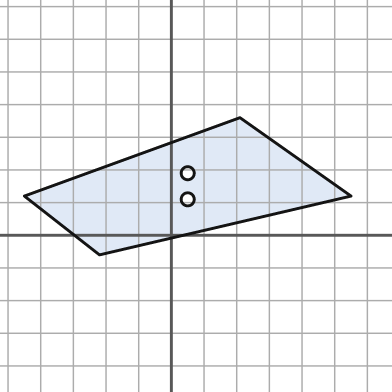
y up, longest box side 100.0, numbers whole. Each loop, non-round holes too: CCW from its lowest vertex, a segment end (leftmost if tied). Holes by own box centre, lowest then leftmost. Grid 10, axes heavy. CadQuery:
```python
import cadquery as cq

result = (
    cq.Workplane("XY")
    .moveTo(-22.0, -6.0)
    .lineTo(55.0, 12.0)
    .lineTo(21.0, 36.0)
    .lineTo(-45.0, 12.0)
    .close()
    .moveTo(5.0, 11.0)
    .circle(2.0)
    .moveTo(5.0, 19.0)
    .circle(2.0)
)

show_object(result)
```